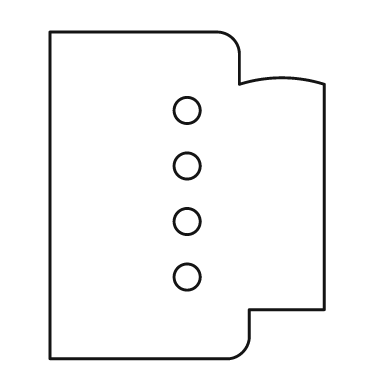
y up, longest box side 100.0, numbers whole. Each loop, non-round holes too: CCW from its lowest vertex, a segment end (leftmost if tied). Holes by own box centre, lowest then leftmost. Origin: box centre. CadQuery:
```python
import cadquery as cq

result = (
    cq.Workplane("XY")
    .moveTo(-42.0, -50.0)
    .lineTo(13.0, -50.0)
    .threePointArc((17.0, -48.0), (19.0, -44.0))
    .lineTo(19.0, -35.0)
    .lineTo(42.0, -35.0)
    .lineTo(42.0, 34.0)
    .threePointArc((29.0, 36.0), (16.0, 34.0))
    .lineTo(16.0, 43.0)
    .threePointArc((14.0, 48.0), (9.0, 50.0))
    .lineTo(-42.0, 50.0)
    .close()
    .moveTo(0.0, -25.0)
    .circle(4.0)
    .moveTo(0.0, -8.0)
    .circle(4.0)
    .moveTo(0.0, 9.0)
    .circle(4.0)
    .moveTo(0.0, 26.0)
    .circle(4.0)
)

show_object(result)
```